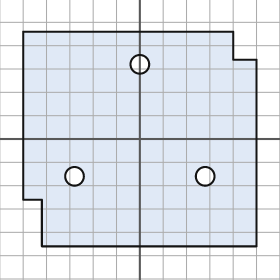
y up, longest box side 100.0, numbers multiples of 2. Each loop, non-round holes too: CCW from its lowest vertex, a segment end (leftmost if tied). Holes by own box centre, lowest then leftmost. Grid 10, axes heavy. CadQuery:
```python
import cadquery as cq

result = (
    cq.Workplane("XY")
    .moveTo(-42.0, -46.0)
    .lineTo(50.0, -46.0)
    .lineTo(50.0, 34.0)
    .lineTo(40.0, 34.0)
    .lineTo(40.0, 46.0)
    .lineTo(-50.0, 46.0)
    .lineTo(-50.0, -26.0)
    .lineTo(-42.0, -26.0)
    .close()
    .moveTo(-28.0, -16.0)
    .circle(4.0)
    .moveTo(28.0, -16.0)
    .circle(4.0)
    .moveTo(0.0, 32.0)
    .circle(4.0)
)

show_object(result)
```